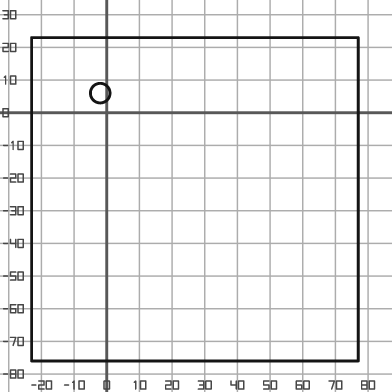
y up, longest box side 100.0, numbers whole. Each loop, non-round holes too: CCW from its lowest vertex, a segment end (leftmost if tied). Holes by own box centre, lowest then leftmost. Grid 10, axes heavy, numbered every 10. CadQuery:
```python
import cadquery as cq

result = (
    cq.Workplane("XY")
    .moveTo(-23.0, -76.0)
    .lineTo(77.0, -76.0)
    .lineTo(77.0, 23.0)
    .lineTo(-23.0, 23.0)
    .close()
    .moveTo(-2.0, 6.0)
    .circle(3.0)
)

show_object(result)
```